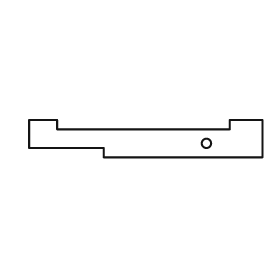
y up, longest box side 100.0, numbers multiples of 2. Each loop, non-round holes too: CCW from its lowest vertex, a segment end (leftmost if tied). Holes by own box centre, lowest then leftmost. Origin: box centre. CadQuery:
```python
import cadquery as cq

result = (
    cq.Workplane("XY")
    .moveTo(-18.0, -8.0)
    .lineTo(50.0, -8.0)
    .lineTo(50.0, 8.0)
    .lineTo(36.0, 8.0)
    .lineTo(36.0, 4.0)
    .lineTo(-38.0, 4.0)
    .lineTo(-38.0, 8.0)
    .lineTo(-50.0, 8.0)
    .lineTo(-50.0, -4.0)
    .lineTo(-18.0, -4.0)
    .close()
    .moveTo(26.0, -2.0)
    .circle(2.0)
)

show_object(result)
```